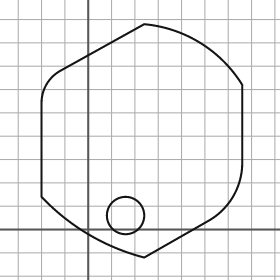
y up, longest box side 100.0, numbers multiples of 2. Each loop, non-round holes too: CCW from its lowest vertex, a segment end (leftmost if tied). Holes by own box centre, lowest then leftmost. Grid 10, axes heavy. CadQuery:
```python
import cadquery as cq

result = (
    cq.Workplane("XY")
    .moveTo(24.0, -12.0)
    .lineTo(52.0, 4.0)
    .threePointArc((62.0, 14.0), (66.0, 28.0))
    .lineTo(66.0, 62.0)
    .threePointArc((48.0, 80.0), (24.0, 88.0))
    .lineTo(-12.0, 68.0)
    .threePointArc((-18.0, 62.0), (-20.0, 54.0))
    .lineTo(-20.0, 14.0)
    .threePointArc((0.0, -2.0), (24.0, -12.0))
    .close()
    .moveTo(16.0, 6.0)
    .circle(8.0)
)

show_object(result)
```